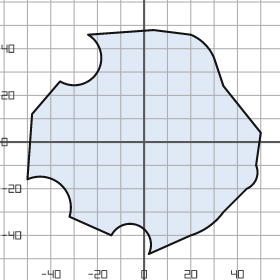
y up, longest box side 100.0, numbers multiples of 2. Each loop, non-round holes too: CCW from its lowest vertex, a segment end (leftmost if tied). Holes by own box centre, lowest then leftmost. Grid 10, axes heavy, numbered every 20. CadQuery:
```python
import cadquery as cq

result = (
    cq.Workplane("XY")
    .moveTo(2.0, -48.0)
    .lineTo(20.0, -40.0)
    .threePointArc((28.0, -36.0), (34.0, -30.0))
    .lineTo(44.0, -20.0)
    .threePointArc((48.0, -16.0), (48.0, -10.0))
    .lineTo(50.0, 4.0)
    .lineTo(34.0, 24.0)
    .lineTo(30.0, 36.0)
    .threePointArc((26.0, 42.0), (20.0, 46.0))
    .lineTo(4.0, 48.0)
    .lineTo(-24.0, 46.0)
    .threePointArc((-20.0, 30.0), (-36.0, 26.0))
    .lineTo(-48.0, 12.0)
    .lineTo(-50.0, -16.0)
    .threePointArc((-36.0, -18.0), (-32.0, -32.0))
    .lineTo(-14.0, -40.0)
    .threePointArc((-2.0, -36.0), (2.0, -48.0))
    .close()
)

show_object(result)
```